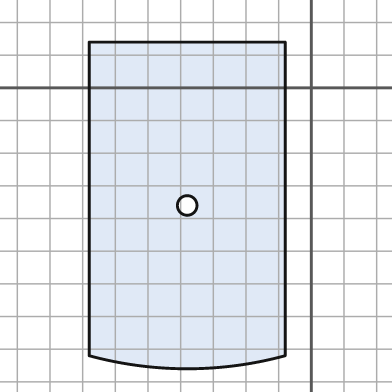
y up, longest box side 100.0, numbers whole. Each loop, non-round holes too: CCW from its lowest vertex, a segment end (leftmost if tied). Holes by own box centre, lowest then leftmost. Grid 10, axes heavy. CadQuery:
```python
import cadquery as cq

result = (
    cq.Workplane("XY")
    .moveTo(-68.0, -82.0)
    .threePointArc((-38.0, -86.0), (-8.0, -82.0))
    .lineTo(-8.0, 14.0)
    .lineTo(-68.0, 14.0)
    .close()
    .moveTo(-38.0, -36.0)
    .circle(3.0)
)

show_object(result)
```